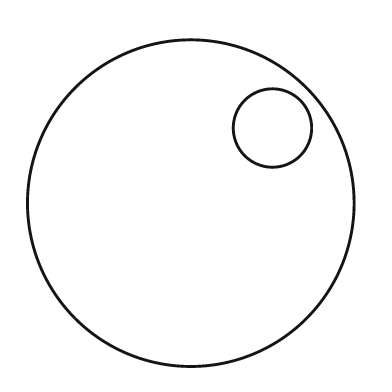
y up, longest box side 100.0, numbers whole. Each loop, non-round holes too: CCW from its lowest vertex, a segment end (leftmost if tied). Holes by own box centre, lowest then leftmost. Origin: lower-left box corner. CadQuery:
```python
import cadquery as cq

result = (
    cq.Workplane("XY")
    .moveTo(50.0, 50.0)
    .circle(50.0)
    .moveTo(75.0, 73.0)
    .circle(12.0)
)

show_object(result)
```